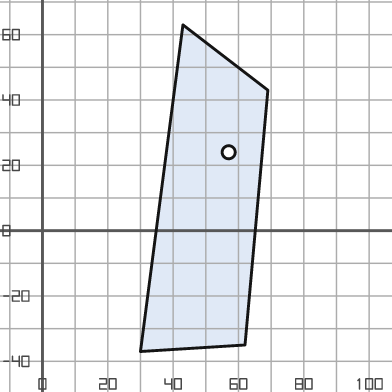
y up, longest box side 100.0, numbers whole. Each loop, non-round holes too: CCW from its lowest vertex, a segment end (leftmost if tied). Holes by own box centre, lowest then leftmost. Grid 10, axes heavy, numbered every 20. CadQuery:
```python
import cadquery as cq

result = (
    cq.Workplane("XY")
    .moveTo(30.0, -37.0)
    .lineTo(62.0, -35.0)
    .lineTo(69.0, 43.0)
    .lineTo(43.0, 63.0)
    .close()
    .moveTo(57.0, 24.0)
    .circle(2.0)
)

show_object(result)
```